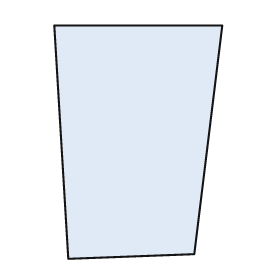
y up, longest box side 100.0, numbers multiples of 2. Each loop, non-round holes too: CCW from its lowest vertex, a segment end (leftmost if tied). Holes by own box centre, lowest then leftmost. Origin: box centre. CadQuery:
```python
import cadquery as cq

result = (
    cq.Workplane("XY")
    .moveTo(-30.0, -50.0)
    .lineTo(24.0, -48.0)
    .lineTo(36.0, 50.0)
    .lineTo(-36.0, 50.0)
    .close()
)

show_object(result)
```